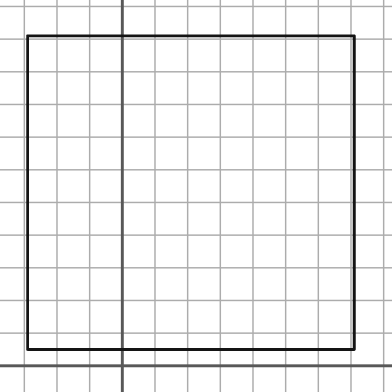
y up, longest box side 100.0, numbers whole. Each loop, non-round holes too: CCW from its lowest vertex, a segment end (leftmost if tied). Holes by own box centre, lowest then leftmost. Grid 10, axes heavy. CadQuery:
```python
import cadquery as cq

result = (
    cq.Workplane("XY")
    .moveTo(-29.0, 5.0)
    .lineTo(71.0, 5.0)
    .lineTo(71.0, 101.0)
    .lineTo(-29.0, 101.0)
    .close()
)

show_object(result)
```